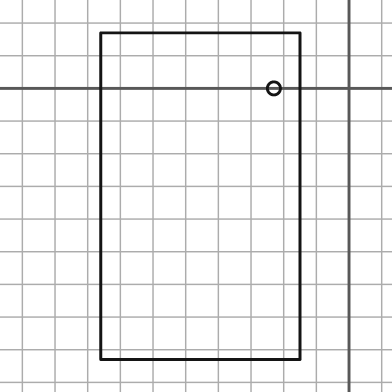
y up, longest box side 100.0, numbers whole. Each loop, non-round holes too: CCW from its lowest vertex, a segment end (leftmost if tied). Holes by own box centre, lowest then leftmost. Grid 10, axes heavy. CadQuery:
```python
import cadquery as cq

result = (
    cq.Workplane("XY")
    .moveTo(-76.0, -83.0)
    .lineTo(-15.0, -83.0)
    .lineTo(-15.0, 17.0)
    .lineTo(-76.0, 17.0)
    .close()
    .moveTo(-23.0, 0.0)
    .circle(2.0)
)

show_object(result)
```